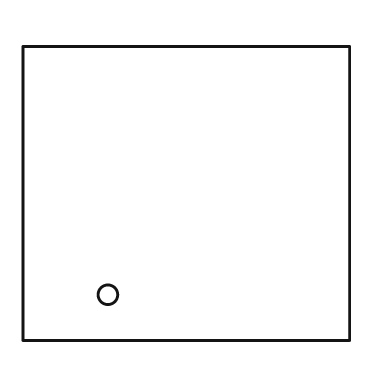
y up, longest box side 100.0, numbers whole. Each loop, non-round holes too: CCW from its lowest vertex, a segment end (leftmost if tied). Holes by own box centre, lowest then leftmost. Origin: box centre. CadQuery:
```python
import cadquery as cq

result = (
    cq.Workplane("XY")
    .moveTo(-50.0, -45.0)
    .lineTo(50.0, -45.0)
    .lineTo(50.0, 45.0)
    .lineTo(-50.0, 45.0)
    .close()
    .moveTo(-24.0, -31.0)
    .circle(3.0)
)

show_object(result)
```